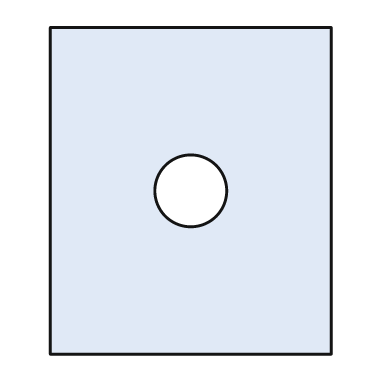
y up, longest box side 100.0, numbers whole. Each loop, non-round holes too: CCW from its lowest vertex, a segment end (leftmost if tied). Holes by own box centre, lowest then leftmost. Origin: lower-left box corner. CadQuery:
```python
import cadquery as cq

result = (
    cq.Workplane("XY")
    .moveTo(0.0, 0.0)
    .lineTo(86.0, 0.0)
    .lineTo(86.0, 100.0)
    .lineTo(0.0, 100.0)
    .close()
    .moveTo(43.0, 50.0)
    .circle(11.0)
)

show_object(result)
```